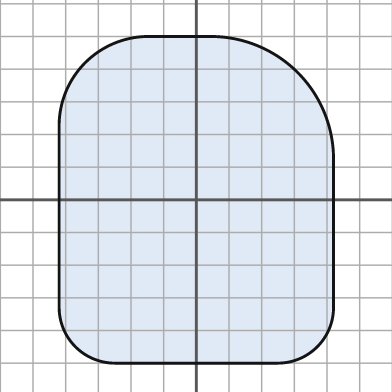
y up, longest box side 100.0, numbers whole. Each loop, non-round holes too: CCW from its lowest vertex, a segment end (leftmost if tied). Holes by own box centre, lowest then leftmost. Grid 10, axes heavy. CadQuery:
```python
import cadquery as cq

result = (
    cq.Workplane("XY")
    .moveTo(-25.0, -50.0)
    .lineTo(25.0, -50.0)
    .threePointArc((37.0, -45.0), (42.0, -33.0))
    .lineTo(42.0, 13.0)
    .threePointArc((31.0, 39.0), (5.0, 50.0))
    .lineTo(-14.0, 50.0)
    .threePointArc((-34.0, 42.0), (-42.0, 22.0))
    .lineTo(-42.0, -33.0)
    .threePointArc((-37.0, -45.0), (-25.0, -50.0))
    .close()
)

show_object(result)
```